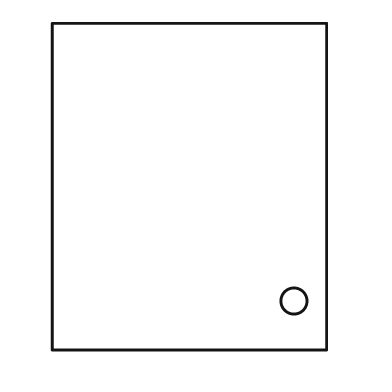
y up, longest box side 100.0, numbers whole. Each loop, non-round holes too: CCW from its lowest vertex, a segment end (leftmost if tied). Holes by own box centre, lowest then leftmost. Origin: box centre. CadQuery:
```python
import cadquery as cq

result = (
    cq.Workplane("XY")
    .moveTo(-42.0, -50.0)
    .lineTo(42.0, -50.0)
    .lineTo(42.0, 50.0)
    .lineTo(-42.0, 50.0)
    .close()
    .moveTo(32.0, -35.0)
    .circle(4.0)
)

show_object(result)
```